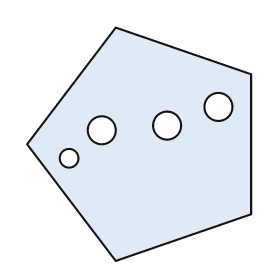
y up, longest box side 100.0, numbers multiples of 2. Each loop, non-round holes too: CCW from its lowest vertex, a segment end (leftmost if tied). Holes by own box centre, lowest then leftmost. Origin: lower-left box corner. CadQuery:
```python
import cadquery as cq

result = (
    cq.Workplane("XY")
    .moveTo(38.0, 0.0)
    .lineTo(96.0, 20.0)
    .lineTo(96.0, 80.0)
    .lineTo(38.0, 100.0)
    .lineTo(0.0, 50.0)
    .close()
    .moveTo(18.0, 44.0)
    .circle(4.0)
    .moveTo(32.0, 56.0)
    .circle(6.0)
    .moveTo(60.0, 58.0)
    .circle(6.0)
    .moveTo(82.0, 66.0)
    .circle(6.0)
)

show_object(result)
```